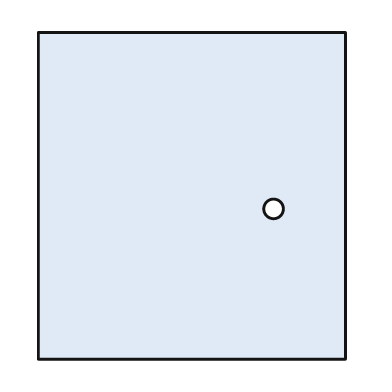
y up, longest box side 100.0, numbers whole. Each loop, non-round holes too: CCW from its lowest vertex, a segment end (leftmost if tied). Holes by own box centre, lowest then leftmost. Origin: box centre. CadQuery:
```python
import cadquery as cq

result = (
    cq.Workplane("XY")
    .moveTo(-47.0, -50.0)
    .lineTo(47.0, -50.0)
    .lineTo(47.0, 50.0)
    .lineTo(-47.0, 50.0)
    .close()
    .moveTo(25.0, -4.0)
    .circle(3.0)
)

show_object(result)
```